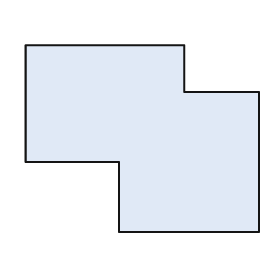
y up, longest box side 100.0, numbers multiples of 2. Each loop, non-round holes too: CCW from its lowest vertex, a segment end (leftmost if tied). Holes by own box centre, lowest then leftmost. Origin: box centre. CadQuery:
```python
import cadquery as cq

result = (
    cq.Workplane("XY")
    .moveTo(-10.0, -40.0)
    .lineTo(50.0, -40.0)
    .lineTo(50.0, 20.0)
    .lineTo(18.0, 20.0)
    .lineTo(18.0, 40.0)
    .lineTo(-50.0, 40.0)
    .lineTo(-50.0, -10.0)
    .lineTo(-10.0, -10.0)
    .close()
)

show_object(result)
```